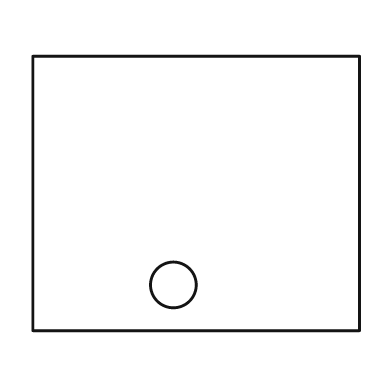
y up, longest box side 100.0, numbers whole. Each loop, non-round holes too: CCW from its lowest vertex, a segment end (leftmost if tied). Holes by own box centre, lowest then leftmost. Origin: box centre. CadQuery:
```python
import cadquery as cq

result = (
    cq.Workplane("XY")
    .moveTo(-50.0, -42.0)
    .lineTo(50.0, -42.0)
    .lineTo(50.0, 42.0)
    .lineTo(-50.0, 42.0)
    .close()
    .moveTo(-7.0, -28.0)
    .circle(7.0)
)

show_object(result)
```